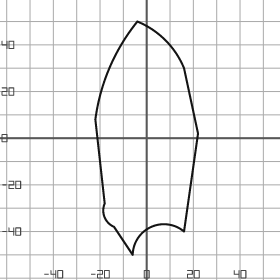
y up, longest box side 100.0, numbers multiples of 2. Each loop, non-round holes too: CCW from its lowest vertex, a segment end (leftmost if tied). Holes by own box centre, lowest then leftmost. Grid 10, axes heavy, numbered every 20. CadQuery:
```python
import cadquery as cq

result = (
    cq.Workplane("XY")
    .moveTo(-6.0, -50.0)
    .threePointArc((2.0, -38.0), (16.0, -40.0))
    .lineTo(22.0, 2.0)
    .lineTo(16.0, 30.0)
    .threePointArc((8.0, 42.0), (-4.0, 50.0))
    .threePointArc((-16.0, 30.0), (-22.0, 8.0))
    .lineTo(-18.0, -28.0)
    .threePointArc((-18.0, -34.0), (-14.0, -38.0))
    .close()
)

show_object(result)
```